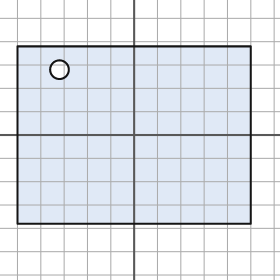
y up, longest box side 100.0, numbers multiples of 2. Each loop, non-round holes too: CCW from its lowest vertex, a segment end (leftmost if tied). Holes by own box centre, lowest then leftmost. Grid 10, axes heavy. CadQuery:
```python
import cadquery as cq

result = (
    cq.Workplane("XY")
    .moveTo(-50.0, -38.0)
    .lineTo(50.0, -38.0)
    .lineTo(50.0, 38.0)
    .lineTo(-50.0, 38.0)
    .close()
    .moveTo(-32.0, 28.0)
    .circle(4.0)
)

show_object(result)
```